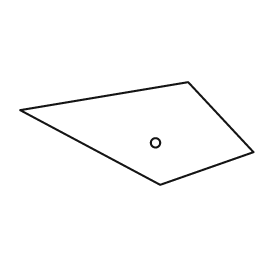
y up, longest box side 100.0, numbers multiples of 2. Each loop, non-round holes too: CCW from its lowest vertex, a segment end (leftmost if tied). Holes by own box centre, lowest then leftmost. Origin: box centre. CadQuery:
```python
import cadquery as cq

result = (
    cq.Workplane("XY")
    .moveTo(10.0, -22.0)
    .lineTo(50.0, -8.0)
    .lineTo(22.0, 22.0)
    .lineTo(-50.0, 10.0)
    .close()
    .moveTo(8.0, -4.0)
    .circle(2.0)
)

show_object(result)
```